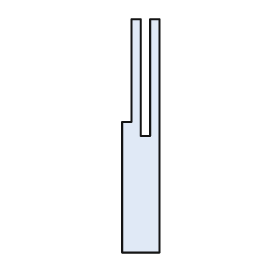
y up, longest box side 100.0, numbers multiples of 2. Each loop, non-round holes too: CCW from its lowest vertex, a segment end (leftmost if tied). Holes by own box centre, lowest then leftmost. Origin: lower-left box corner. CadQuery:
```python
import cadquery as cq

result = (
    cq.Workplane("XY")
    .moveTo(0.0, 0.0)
    .lineTo(16.0, 0.0)
    .lineTo(16.0, 100.0)
    .lineTo(12.0, 100.0)
    .lineTo(12.0, 50.0)
    .lineTo(8.0, 50.0)
    .lineTo(8.0, 100.0)
    .lineTo(4.0, 100.0)
    .lineTo(4.0, 56.0)
    .lineTo(0.0, 56.0)
    .close()
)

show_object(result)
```